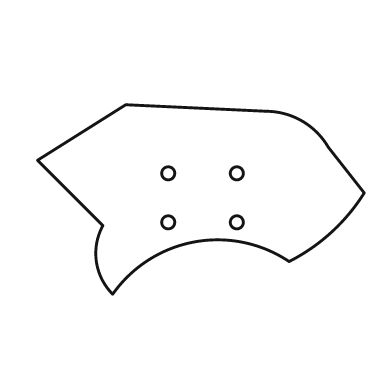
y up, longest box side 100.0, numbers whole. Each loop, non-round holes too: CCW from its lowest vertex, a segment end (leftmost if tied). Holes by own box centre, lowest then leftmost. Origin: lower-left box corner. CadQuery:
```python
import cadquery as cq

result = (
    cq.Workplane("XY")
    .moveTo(23.0, 0.0)
    .threePointArc((48.0, 16.0), (77.0, 10.0))
    .threePointArc((90.0, 19.0), (100.0, 31.0))
    .lineTo(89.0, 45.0)
    .threePointArc((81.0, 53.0), (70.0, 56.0))
    .lineTo(27.0, 58.0)
    .lineTo(0.0, 41.0)
    .lineTo(20.0, 21.0)
    .threePointArc((18.0, 10.0), (23.0, 0.0))
    .close()
    .moveTo(40.0, 22.0)
    .circle(2.0)
    .moveTo(61.0, 22.0)
    .circle(2.0)
    .moveTo(40.0, 37.0)
    .circle(2.0)
    .moveTo(61.0, 37.0)
    .circle(2.0)
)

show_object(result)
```